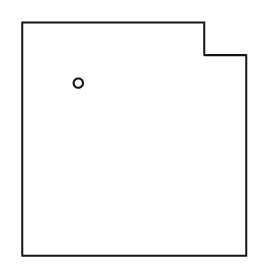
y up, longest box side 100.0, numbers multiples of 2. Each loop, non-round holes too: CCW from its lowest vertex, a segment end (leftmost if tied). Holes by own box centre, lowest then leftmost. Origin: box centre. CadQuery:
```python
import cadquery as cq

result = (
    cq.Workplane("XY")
    .moveTo(-48.0, -50.0)
    .lineTo(48.0, -50.0)
    .lineTo(48.0, 36.0)
    .lineTo(30.0, 36.0)
    .lineTo(30.0, 50.0)
    .lineTo(-48.0, 50.0)
    .close()
    .moveTo(-24.0, 24.0)
    .circle(2.0)
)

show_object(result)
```